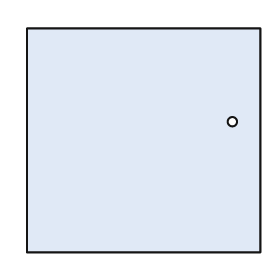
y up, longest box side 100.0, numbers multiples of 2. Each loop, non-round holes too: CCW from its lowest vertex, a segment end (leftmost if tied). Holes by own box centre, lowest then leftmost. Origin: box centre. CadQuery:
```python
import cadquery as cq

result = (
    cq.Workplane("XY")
    .moveTo(-50.0, -48.0)
    .lineTo(50.0, -48.0)
    .lineTo(50.0, 48.0)
    .lineTo(-50.0, 48.0)
    .close()
    .moveTo(38.0, 8.0)
    .circle(2.0)
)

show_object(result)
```